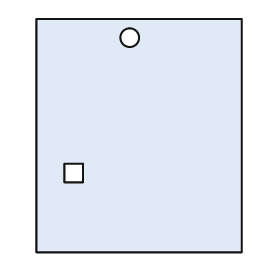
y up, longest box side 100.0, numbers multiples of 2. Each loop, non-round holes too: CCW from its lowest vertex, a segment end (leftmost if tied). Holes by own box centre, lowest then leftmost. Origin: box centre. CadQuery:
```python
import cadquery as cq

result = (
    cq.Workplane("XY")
    .moveTo(-44.0, -50.0)
    .lineTo(44.0, -50.0)
    .lineTo(44.0, 50.0)
    .lineTo(-44.0, 50.0)
    .close()
    .moveTo(-32.0, -20.0)
    .lineTo(-24.0, -20.0)
    .lineTo(-24.0, -12.0)
    .lineTo(-32.0, -12.0)
    .close()
    .moveTo(-4.0, 42.0)
    .circle(4.0)
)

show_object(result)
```